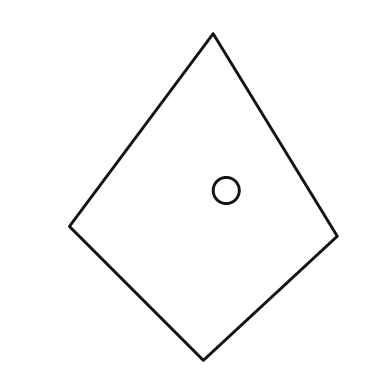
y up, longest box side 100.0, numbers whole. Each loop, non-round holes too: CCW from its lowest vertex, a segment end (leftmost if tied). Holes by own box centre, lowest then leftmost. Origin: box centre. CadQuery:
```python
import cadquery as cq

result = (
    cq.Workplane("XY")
    .moveTo(0.0, -50.0)
    .lineTo(41.0, -12.0)
    .lineTo(3.0, 50.0)
    .lineTo(-41.0, -9.0)
    .close()
    .moveTo(7.0, 2.0)
    .circle(4.0)
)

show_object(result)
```